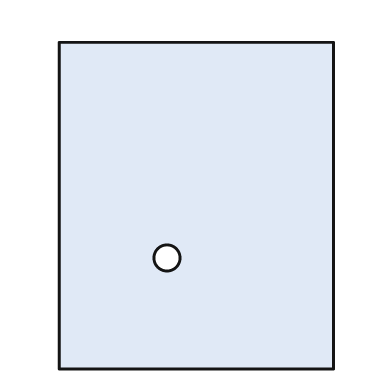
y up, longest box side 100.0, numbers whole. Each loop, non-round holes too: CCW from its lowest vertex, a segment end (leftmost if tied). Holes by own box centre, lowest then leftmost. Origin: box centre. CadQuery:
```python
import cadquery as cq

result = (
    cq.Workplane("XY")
    .moveTo(-42.0, -50.0)
    .lineTo(42.0, -50.0)
    .lineTo(42.0, 50.0)
    .lineTo(-42.0, 50.0)
    .close()
    .moveTo(-9.0, -16.0)
    .circle(4.0)
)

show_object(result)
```